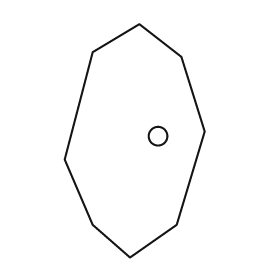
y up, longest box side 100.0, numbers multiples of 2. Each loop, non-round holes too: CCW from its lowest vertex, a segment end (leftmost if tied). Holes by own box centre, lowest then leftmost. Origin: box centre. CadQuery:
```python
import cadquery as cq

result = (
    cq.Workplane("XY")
    .moveTo(-2.0, -50.0)
    .lineTo(18.0, -36.0)
    .lineTo(30.0, 4.0)
    .lineTo(20.0, 36.0)
    .lineTo(2.0, 50.0)
    .lineTo(-18.0, 38.0)
    .lineTo(-30.0, -8.0)
    .lineTo(-18.0, -36.0)
    .close()
    .moveTo(10.0, 2.0)
    .circle(4.0)
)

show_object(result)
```